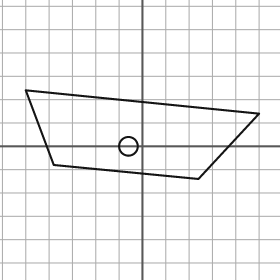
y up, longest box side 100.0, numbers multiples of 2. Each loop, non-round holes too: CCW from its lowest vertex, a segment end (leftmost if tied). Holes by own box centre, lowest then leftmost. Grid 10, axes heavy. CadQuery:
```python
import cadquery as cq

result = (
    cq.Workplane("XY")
    .moveTo(24.0, -14.0)
    .lineTo(50.0, 14.0)
    .lineTo(-50.0, 24.0)
    .lineTo(-38.0, -8.0)
    .close()
    .moveTo(-6.0, 0.0)
    .circle(4.0)
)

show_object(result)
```